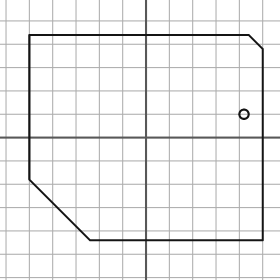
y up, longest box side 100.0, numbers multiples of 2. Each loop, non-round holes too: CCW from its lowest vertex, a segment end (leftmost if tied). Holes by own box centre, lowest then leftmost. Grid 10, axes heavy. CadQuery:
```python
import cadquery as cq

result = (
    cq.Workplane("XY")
    .moveTo(-24.0, -44.0)
    .lineTo(50.0, -44.0)
    .lineTo(50.0, 38.0)
    .lineTo(44.0, 44.0)
    .lineTo(-50.0, 44.0)
    .lineTo(-50.0, -18.0)
    .close()
    .moveTo(42.0, 10.0)
    .circle(2.0)
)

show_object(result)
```